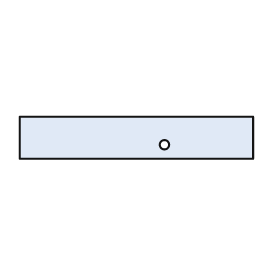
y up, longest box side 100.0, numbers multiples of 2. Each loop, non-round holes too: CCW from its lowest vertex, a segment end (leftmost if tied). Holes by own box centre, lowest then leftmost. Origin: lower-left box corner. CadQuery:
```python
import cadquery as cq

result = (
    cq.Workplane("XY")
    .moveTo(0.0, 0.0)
    .lineTo(100.0, 0.0)
    .lineTo(100.0, 18.0)
    .lineTo(0.0, 18.0)
    .close()
    .moveTo(62.0, 6.0)
    .circle(2.0)
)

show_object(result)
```